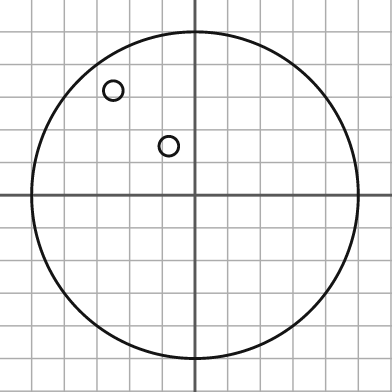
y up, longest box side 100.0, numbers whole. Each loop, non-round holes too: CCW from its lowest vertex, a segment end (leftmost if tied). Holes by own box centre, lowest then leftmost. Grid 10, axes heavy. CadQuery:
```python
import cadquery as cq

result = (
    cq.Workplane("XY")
    .moveTo(0.0, 0.0)
    .circle(50.0)
    .moveTo(-8.0, 15.0)
    .circle(3.0)
    .moveTo(-25.0, 32.0)
    .circle(3.0)
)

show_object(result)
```